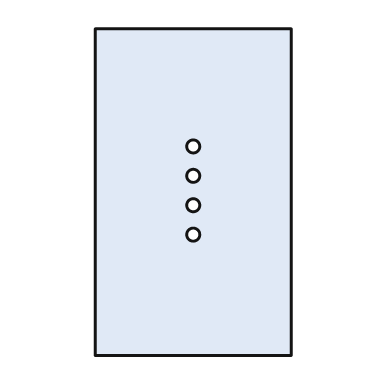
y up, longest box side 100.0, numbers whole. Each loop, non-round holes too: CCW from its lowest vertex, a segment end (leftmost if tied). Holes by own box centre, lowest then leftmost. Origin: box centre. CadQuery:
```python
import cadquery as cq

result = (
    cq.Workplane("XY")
    .moveTo(-30.0, -50.0)
    .lineTo(30.0, -50.0)
    .lineTo(30.0, 50.0)
    .lineTo(-30.0, 50.0)
    .close()
    .moveTo(0.0, -13.0)
    .circle(2.0)
    .moveTo(0.0, -4.0)
    .circle(2.0)
    .moveTo(0.0, 5.0)
    .circle(2.0)
    .moveTo(0.0, 14.0)
    .circle(2.0)
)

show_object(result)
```